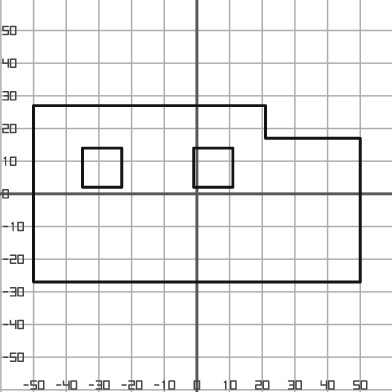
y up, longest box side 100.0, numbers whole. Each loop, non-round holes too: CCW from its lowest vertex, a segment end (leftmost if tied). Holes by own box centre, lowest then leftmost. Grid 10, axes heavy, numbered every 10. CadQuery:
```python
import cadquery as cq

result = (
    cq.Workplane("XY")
    .moveTo(-50.0, -27.0)
    .lineTo(50.0, -27.0)
    .lineTo(50.0, 17.0)
    .lineTo(21.0, 17.0)
    .lineTo(21.0, 27.0)
    .lineTo(-50.0, 27.0)
    .close()
    .moveTo(-35.0, 2.0)
    .lineTo(-23.0, 2.0)
    .lineTo(-23.0, 14.0)
    .lineTo(-35.0, 14.0)
    .close()
    .moveTo(-1.0, 2.0)
    .lineTo(11.0, 2.0)
    .lineTo(11.0, 14.0)
    .lineTo(-1.0, 14.0)
    .close()
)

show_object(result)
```